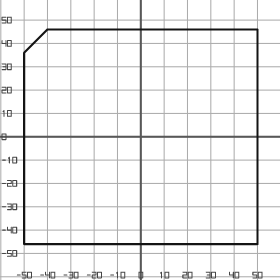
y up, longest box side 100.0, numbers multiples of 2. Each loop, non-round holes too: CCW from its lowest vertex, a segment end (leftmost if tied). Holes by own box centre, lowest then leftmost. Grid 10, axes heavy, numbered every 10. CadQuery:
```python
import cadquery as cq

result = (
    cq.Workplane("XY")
    .moveTo(-50.0, -46.0)
    .lineTo(50.0, -46.0)
    .lineTo(50.0, 46.0)
    .lineTo(-40.0, 46.0)
    .lineTo(-50.0, 36.0)
    .close()
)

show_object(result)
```